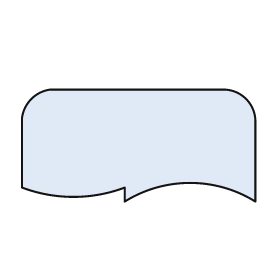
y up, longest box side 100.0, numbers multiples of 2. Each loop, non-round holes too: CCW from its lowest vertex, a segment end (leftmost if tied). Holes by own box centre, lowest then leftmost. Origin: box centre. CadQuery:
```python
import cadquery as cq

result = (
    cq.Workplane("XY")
    .moveTo(-6.0, -24.0)
    .threePointArc((22.0, -16.0), (50.0, -24.0))
    .lineTo(50.0, 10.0)
    .threePointArc((46.0, 20.0), (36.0, 24.0))
    .lineTo(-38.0, 24.0)
    .threePointArc((-46.0, 20.0), (-50.0, 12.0))
    .lineTo(-50.0, -18.0)
    .threePointArc((-28.0, -22.0), (-6.0, -18.0))
    .close()
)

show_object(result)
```